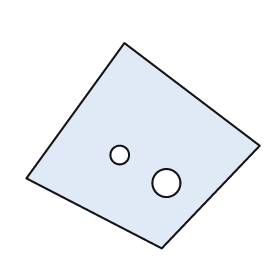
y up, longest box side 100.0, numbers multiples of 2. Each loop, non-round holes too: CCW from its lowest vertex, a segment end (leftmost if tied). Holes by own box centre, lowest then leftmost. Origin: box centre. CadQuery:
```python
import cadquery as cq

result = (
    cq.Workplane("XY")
    .moveTo(8.0, -44.0)
    .lineTo(50.0, 0.0)
    .lineTo(-8.0, 44.0)
    .lineTo(-50.0, -14.0)
    .close()
    .moveTo(10.0, -16.0)
    .circle(6.0)
    .moveTo(-10.0, -4.0)
    .circle(4.0)
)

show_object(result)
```